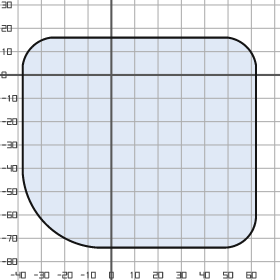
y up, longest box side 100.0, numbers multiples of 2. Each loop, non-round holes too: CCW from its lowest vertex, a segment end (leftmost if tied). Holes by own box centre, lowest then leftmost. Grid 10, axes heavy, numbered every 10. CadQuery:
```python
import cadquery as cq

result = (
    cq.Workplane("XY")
    .moveTo(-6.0, -74.0)
    .lineTo(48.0, -74.0)
    .threePointArc((58.0, -70.0), (62.0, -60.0))
    .lineTo(62.0, 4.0)
    .threePointArc((58.0, 12.0), (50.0, 16.0))
    .lineTo(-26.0, 16.0)
    .threePointArc((-34.0, 12.0), (-38.0, 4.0))
    .lineTo(-38.0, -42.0)
    .threePointArc((-28.0, -64.0), (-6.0, -74.0))
    .close()
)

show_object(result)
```